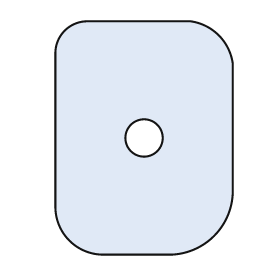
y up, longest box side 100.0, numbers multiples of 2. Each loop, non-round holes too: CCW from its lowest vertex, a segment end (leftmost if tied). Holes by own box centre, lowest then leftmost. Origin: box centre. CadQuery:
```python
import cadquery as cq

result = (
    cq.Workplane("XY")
    .moveTo(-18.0, -50.0)
    .lineTo(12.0, -50.0)
    .threePointArc((30.0, -42.0), (38.0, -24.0))
    .lineTo(38.0, 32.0)
    .threePointArc((32.0, 44.0), (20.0, 50.0))
    .lineTo(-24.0, 50.0)
    .threePointArc((-34.0, 46.0), (-38.0, 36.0))
    .lineTo(-38.0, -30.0)
    .threePointArc((-32.0, -44.0), (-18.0, -50.0))
    .close()
    .moveTo(0.0, 0.0)
    .circle(8.0)
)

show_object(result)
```